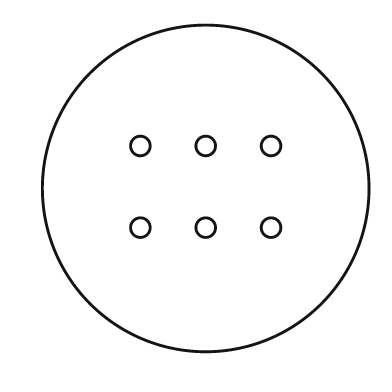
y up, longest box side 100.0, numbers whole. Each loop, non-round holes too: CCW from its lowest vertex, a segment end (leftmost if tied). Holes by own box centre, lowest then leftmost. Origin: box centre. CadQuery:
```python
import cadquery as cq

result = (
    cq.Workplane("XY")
    .moveTo(0.0, 0.0)
    .circle(50.0)
    .moveTo(-20.0, -12.0)
    .circle(3.0)
    .moveTo(0.0, -12.0)
    .circle(3.0)
    .moveTo(20.0, -12.0)
    .circle(3.0)
    .moveTo(-20.0, 13.0)
    .circle(3.0)
    .moveTo(0.0, 13.0)
    .circle(3.0)
    .moveTo(20.0, 13.0)
    .circle(3.0)
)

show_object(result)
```